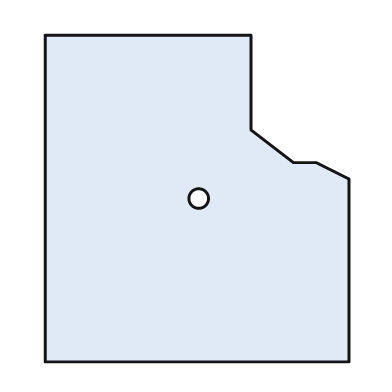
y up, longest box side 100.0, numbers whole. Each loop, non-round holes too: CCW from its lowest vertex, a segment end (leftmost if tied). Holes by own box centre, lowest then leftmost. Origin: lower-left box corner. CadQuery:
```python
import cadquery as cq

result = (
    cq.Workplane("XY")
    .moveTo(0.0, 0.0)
    .lineTo(93.0, 0.0)
    .lineTo(93.0, 56.0)
    .lineTo(83.0, 61.0)
    .lineTo(76.0, 61.0)
    .lineTo(63.0, 71.0)
    .lineTo(63.0, 100.0)
    .lineTo(0.0, 100.0)
    .close()
    .moveTo(47.0, 50.0)
    .circle(3.0)
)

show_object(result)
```